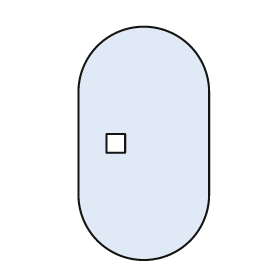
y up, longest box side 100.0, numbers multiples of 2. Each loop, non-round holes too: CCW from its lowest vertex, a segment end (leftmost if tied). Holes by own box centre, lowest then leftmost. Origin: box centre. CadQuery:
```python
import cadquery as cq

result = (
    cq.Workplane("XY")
    .moveTo(-28.0, -22.0)
    .threePointArc((0.0, -50.0), (28.0, -22.0))
    .lineTo(28.0, 22.0)
    .threePointArc((0.0, 50.0), (-28.0, 22.0))
    .close()
    .moveTo(-16.0, -4.0)
    .lineTo(-8.0, -4.0)
    .lineTo(-8.0, 4.0)
    .lineTo(-16.0, 4.0)
    .close()
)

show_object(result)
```